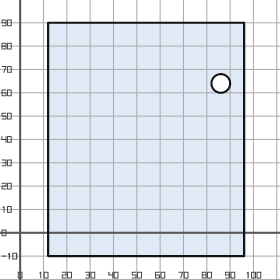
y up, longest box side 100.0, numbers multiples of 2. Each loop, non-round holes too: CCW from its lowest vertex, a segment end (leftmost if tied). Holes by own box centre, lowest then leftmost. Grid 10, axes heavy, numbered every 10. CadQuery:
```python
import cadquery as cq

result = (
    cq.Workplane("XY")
    .moveTo(12.0, -10.0)
    .lineTo(96.0, -10.0)
    .lineTo(96.0, 90.0)
    .lineTo(12.0, 90.0)
    .close()
    .moveTo(86.0, 64.0)
    .circle(4.0)
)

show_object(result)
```